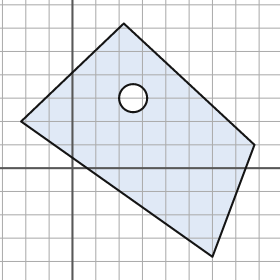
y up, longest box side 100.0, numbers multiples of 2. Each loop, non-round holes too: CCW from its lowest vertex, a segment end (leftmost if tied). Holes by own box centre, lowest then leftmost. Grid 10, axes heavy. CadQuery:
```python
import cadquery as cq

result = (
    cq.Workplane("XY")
    .moveTo(60.0, -38.0)
    .lineTo(78.0, 10.0)
    .lineTo(22.0, 62.0)
    .lineTo(-22.0, 20.0)
    .close()
    .moveTo(26.0, 30.0)
    .circle(6.0)
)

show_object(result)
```